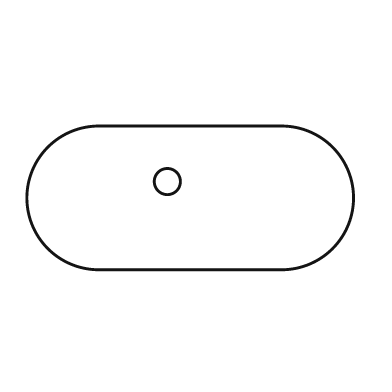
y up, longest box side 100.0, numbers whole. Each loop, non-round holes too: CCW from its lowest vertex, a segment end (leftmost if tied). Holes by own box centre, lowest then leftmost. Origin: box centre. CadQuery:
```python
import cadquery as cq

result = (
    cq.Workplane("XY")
    .moveTo(-28.0, -22.0)
    .lineTo(28.0, -22.0)
    .threePointArc((50.0, 0.0), (28.0, 22.0))
    .lineTo(-28.0, 22.0)
    .threePointArc((-50.0, 0.0), (-28.0, -22.0))
    .close()
    .moveTo(-7.0, 5.0)
    .circle(4.0)
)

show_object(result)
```